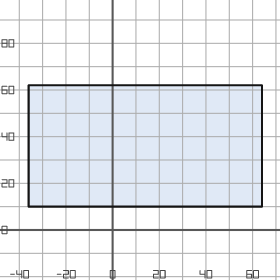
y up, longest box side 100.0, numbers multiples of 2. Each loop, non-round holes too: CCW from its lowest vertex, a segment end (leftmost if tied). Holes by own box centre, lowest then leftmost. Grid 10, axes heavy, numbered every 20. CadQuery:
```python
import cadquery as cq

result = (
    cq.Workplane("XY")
    .moveTo(-36.0, 10.0)
    .lineTo(64.0, 10.0)
    .lineTo(64.0, 62.0)
    .lineTo(-36.0, 62.0)
    .close()
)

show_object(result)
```